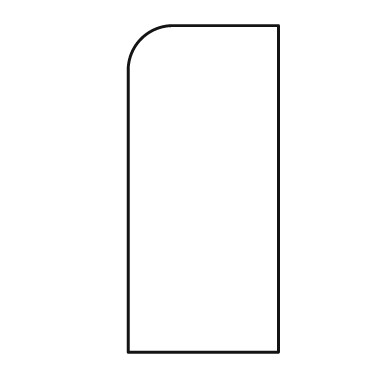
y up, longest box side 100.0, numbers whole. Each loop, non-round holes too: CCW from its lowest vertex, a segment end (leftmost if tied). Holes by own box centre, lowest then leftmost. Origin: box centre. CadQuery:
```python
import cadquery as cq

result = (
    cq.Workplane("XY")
    .moveTo(-23.0, -50.0)
    .lineTo(23.0, -50.0)
    .lineTo(23.0, 50.0)
    .lineTo(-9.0, 50.0)
    .threePointArc((-19.0, 46.0), (-23.0, 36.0))
    .close()
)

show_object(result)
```